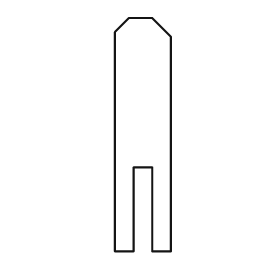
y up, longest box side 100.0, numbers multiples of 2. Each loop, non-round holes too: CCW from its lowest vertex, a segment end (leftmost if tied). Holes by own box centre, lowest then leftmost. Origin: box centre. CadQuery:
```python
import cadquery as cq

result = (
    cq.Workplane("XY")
    .moveTo(-12.0, -50.0)
    .lineTo(-4.0, -50.0)
    .lineTo(-4.0, -14.0)
    .lineTo(4.0, -14.0)
    .lineTo(4.0, -50.0)
    .lineTo(12.0, -50.0)
    .lineTo(12.0, 42.0)
    .lineTo(4.0, 50.0)
    .lineTo(-6.0, 50.0)
    .lineTo(-12.0, 44.0)
    .close()
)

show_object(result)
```